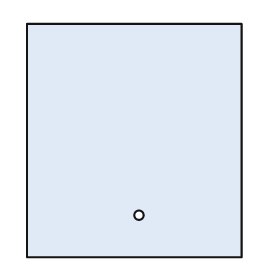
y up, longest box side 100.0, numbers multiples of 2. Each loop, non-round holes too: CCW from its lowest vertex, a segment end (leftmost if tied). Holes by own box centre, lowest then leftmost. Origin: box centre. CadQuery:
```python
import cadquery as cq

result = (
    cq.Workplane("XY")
    .moveTo(-46.0, -50.0)
    .lineTo(46.0, -50.0)
    .lineTo(46.0, 50.0)
    .lineTo(-46.0, 50.0)
    .close()
    .moveTo(2.0, -32.0)
    .circle(2.0)
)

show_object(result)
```